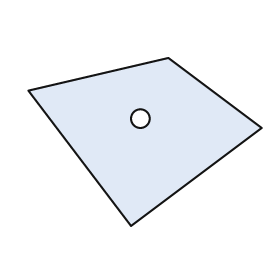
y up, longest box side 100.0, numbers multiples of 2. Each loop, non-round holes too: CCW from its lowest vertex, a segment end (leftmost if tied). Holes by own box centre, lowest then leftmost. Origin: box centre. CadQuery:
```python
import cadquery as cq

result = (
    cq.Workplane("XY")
    .moveTo(-6.0, -36.0)
    .lineTo(50.0, 6.0)
    .lineTo(10.0, 36.0)
    .lineTo(-50.0, 22.0)
    .close()
    .moveTo(-2.0, 10.0)
    .circle(4.0)
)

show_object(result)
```